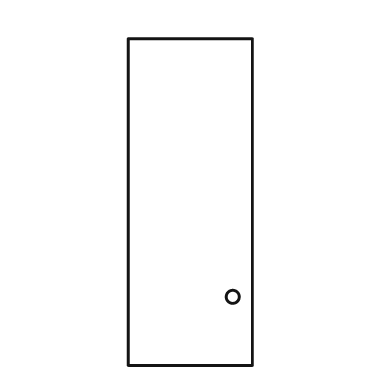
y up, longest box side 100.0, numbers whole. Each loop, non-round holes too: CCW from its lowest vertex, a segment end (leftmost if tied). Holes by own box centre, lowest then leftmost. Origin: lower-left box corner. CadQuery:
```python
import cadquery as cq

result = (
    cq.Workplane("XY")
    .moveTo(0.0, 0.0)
    .lineTo(38.0, 0.0)
    .lineTo(38.0, 100.0)
    .lineTo(0.0, 100.0)
    .close()
    .moveTo(32.0, 21.0)
    .circle(2.0)
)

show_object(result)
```